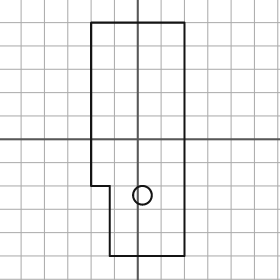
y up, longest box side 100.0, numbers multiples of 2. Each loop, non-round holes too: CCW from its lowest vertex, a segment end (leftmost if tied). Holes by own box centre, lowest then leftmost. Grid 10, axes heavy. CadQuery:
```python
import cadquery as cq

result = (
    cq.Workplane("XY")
    .moveTo(-12.0, -50.0)
    .lineTo(20.0, -50.0)
    .lineTo(20.0, 50.0)
    .lineTo(-20.0, 50.0)
    .lineTo(-20.0, -20.0)
    .lineTo(-12.0, -20.0)
    .close()
    .moveTo(2.0, -24.0)
    .circle(4.0)
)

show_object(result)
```